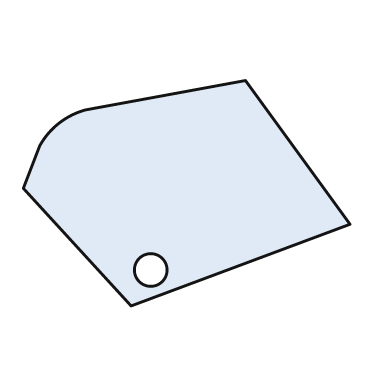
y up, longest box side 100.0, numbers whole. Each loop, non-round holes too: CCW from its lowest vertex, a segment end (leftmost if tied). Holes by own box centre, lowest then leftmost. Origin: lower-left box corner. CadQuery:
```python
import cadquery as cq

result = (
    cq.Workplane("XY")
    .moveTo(33.0, 0.0)
    .lineTo(100.0, 25.0)
    .lineTo(68.0, 69.0)
    .lineTo(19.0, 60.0)
    .threePointArc((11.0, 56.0), (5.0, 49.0))
    .lineTo(0.0, 36.0)
    .close()
    .moveTo(39.0, 11.0)
    .circle(5.0)
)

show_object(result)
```